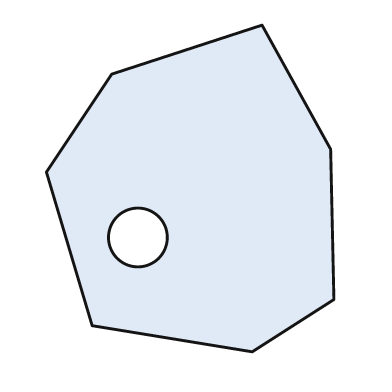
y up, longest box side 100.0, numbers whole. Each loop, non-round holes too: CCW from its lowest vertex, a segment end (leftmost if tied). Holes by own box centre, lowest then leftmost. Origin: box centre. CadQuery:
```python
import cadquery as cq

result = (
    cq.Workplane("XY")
    .moveTo(19.0, -50.0)
    .lineTo(44.0, -34.0)
    .lineTo(43.0, 12.0)
    .lineTo(22.0, 50.0)
    .lineTo(-24.0, 35.0)
    .lineTo(-44.0, 5.0)
    .lineTo(-30.0, -42.0)
    .close()
    .moveTo(-16.0, -15.0)
    .circle(9.0)
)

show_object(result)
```